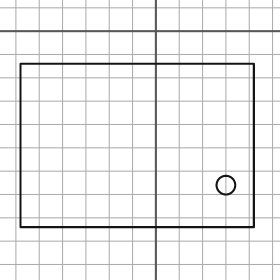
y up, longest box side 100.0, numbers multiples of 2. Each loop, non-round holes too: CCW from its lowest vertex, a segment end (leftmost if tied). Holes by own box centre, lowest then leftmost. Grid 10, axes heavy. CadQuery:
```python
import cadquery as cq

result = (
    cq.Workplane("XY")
    .moveTo(-58.0, -84.0)
    .lineTo(42.0, -84.0)
    .lineTo(42.0, -14.0)
    .lineTo(-58.0, -14.0)
    .close()
    .moveTo(30.0, -66.0)
    .circle(4.0)
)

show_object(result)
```